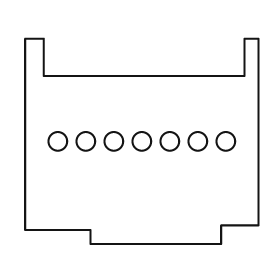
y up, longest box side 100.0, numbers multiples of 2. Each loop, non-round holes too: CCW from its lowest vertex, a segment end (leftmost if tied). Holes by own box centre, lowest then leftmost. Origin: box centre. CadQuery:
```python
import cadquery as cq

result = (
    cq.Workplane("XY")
    .moveTo(-22.0, -44.0)
    .lineTo(34.0, -44.0)
    .lineTo(34.0, -36.0)
    .lineTo(50.0, -36.0)
    .lineTo(50.0, 44.0)
    .lineTo(44.0, 44.0)
    .lineTo(44.0, 28.0)
    .lineTo(-42.0, 28.0)
    .lineTo(-42.0, 44.0)
    .lineTo(-50.0, 44.0)
    .lineTo(-50.0, -38.0)
    .lineTo(-22.0, -38.0)
    .close()
    .moveTo(-36.0, 0.0)
    .circle(4.0)
    .moveTo(-24.0, 0.0)
    .circle(4.0)
    .moveTo(-12.0, 0.0)
    .circle(4.0)
    .moveTo(0.0, 0.0)
    .circle(4.0)
    .moveTo(12.0, 0.0)
    .circle(4.0)
    .moveTo(24.0, 0.0)
    .circle(4.0)
    .moveTo(36.0, 0.0)
    .circle(4.0)
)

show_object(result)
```